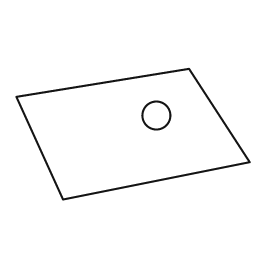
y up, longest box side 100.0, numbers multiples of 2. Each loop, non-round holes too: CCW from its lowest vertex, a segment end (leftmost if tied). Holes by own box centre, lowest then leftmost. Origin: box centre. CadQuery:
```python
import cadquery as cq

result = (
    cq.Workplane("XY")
    .moveTo(-30.0, -28.0)
    .lineTo(50.0, -12.0)
    .lineTo(24.0, 28.0)
    .lineTo(-50.0, 16.0)
    .close()
    .moveTo(10.0, 8.0)
    .circle(6.0)
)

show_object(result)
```